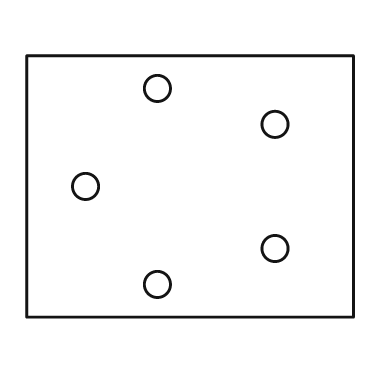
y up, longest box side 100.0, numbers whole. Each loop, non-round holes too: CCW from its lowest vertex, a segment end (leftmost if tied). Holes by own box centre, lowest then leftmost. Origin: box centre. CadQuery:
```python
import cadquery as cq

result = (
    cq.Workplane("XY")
    .moveTo(-50.0, -40.0)
    .lineTo(50.0, -40.0)
    .lineTo(50.0, 40.0)
    .lineTo(-50.0, 40.0)
    .close()
    .moveTo(-10.0, -30.0)
    .circle(4.0)
    .moveTo(26.0, -19.0)
    .circle(4.0)
    .moveTo(-32.0, 0.0)
    .circle(4.0)
    .moveTo(26.0, 19.0)
    .circle(4.0)
    .moveTo(-10.0, 30.0)
    .circle(4.0)
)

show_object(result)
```